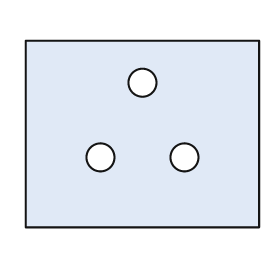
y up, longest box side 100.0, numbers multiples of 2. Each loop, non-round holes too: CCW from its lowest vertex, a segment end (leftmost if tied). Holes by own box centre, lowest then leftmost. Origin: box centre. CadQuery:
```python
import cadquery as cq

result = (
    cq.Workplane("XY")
    .moveTo(-50.0, -40.0)
    .lineTo(50.0, -40.0)
    .lineTo(50.0, 40.0)
    .lineTo(-50.0, 40.0)
    .close()
    .moveTo(-18.0, -10.0)
    .circle(6.0)
    .moveTo(18.0, -10.0)
    .circle(6.0)
    .moveTo(0.0, 22.0)
    .circle(6.0)
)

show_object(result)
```